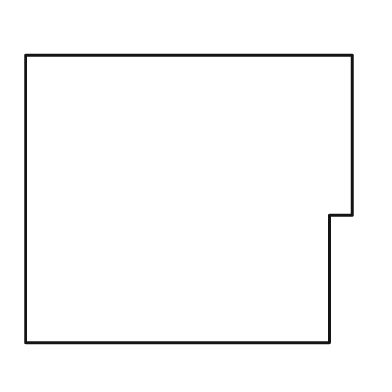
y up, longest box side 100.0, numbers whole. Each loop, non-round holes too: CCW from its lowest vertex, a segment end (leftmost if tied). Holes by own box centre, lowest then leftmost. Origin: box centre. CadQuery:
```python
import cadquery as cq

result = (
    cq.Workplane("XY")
    .moveTo(-50.0, -44.0)
    .lineTo(43.0, -44.0)
    .lineTo(43.0, -5.0)
    .lineTo(50.0, -5.0)
    .lineTo(50.0, 44.0)
    .lineTo(-50.0, 44.0)
    .close()
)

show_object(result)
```